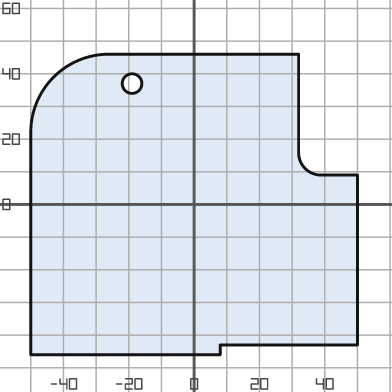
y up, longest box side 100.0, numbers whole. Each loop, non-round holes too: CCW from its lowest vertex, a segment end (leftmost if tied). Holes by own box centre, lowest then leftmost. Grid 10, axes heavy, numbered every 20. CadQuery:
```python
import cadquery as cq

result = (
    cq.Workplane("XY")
    .moveTo(-50.0, -46.0)
    .lineTo(8.0, -46.0)
    .lineTo(8.0, -43.0)
    .lineTo(50.0, -43.0)
    .lineTo(50.0, 9.0)
    .lineTo(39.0, 9.0)
    .threePointArc((34.0, 11.0), (32.0, 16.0))
    .lineTo(32.0, 46.0)
    .lineTo(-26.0, 46.0)
    .threePointArc((-43.0, 39.0), (-50.0, 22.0))
    .close()
    .moveTo(-19.0, 37.0)
    .circle(3.0)
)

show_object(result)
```